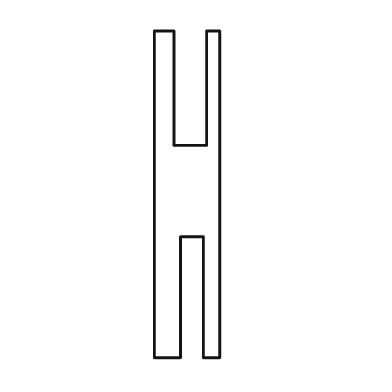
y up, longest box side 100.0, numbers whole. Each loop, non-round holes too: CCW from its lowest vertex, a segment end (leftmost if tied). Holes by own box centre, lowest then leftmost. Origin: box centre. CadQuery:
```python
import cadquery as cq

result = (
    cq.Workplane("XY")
    .moveTo(-10.0, -50.0)
    .lineTo(-2.0, -50.0)
    .lineTo(-2.0, -13.0)
    .lineTo(5.0, -13.0)
    .lineTo(5.0, -50.0)
    .lineTo(10.0, -50.0)
    .lineTo(10.0, 50.0)
    .lineTo(6.0, 50.0)
    .lineTo(6.0, 15.0)
    .lineTo(-4.0, 15.0)
    .lineTo(-4.0, 50.0)
    .lineTo(-10.0, 50.0)
    .close()
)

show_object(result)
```